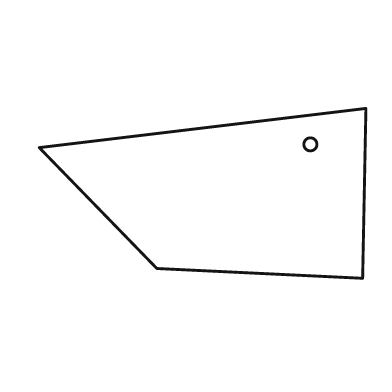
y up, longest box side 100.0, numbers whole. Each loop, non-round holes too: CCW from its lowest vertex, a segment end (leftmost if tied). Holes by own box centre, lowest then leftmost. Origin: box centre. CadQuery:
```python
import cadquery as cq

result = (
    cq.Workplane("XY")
    .moveTo(49.0, -26.0)
    .lineTo(50.0, 26.0)
    .lineTo(-50.0, 14.0)
    .lineTo(-14.0, -23.0)
    .close()
    .moveTo(33.0, 15.0)
    .circle(2.0)
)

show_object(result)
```